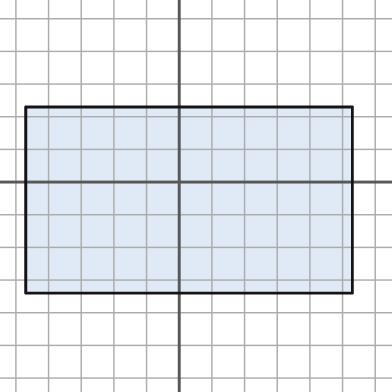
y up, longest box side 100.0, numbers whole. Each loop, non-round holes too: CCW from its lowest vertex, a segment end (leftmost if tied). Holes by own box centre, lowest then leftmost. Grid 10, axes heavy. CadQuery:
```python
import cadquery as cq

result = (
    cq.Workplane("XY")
    .moveTo(-47.0, -34.0)
    .lineTo(53.0, -34.0)
    .lineTo(53.0, 23.0)
    .lineTo(-47.0, 23.0)
    .close()
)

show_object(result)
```